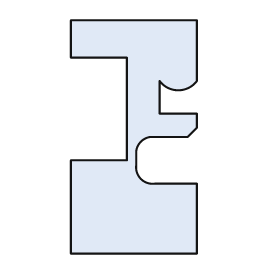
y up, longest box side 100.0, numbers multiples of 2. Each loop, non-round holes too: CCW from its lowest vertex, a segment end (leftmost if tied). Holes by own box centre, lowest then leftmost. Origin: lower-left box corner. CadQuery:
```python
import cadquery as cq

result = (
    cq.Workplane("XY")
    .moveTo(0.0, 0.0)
    .lineTo(54.0, 0.0)
    .lineTo(54.0, 30.0)
    .lineTo(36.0, 30.0)
    .threePointArc((30.0, 32.0), (28.0, 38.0))
    .lineTo(28.0, 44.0)
    .threePointArc((30.0, 48.0), (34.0, 50.0))
    .lineTo(50.0, 50.0)
    .lineTo(54.0, 54.0)
    .lineTo(54.0, 60.0)
    .lineTo(38.0, 60.0)
    .lineTo(38.0, 74.0)
    .threePointArc((46.0, 70.0), (54.0, 74.0))
    .lineTo(54.0, 100.0)
    .lineTo(0.0, 100.0)
    .lineTo(0.0, 84.0)
    .lineTo(24.0, 84.0)
    .lineTo(24.0, 40.0)
    .lineTo(0.0, 40.0)
    .close()
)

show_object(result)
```